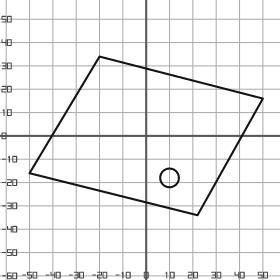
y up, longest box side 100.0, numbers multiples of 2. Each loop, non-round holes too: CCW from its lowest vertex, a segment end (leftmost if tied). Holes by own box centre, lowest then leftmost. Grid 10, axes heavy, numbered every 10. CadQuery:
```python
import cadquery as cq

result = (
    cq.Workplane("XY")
    .moveTo(22.0, -34.0)
    .lineTo(50.0, 16.0)
    .lineTo(-20.0, 34.0)
    .lineTo(-50.0, -16.0)
    .close()
    .moveTo(10.0, -18.0)
    .circle(4.0)
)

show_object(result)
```